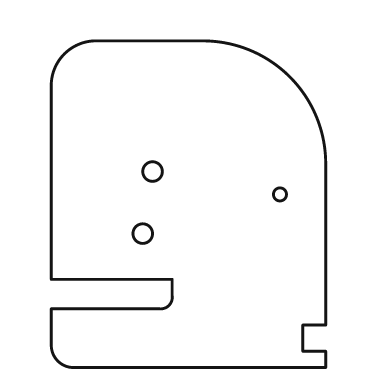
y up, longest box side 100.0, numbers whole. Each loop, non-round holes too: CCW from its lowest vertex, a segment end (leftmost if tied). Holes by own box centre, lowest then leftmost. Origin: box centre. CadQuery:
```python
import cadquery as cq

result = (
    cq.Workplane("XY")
    .moveTo(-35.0, -50.0)
    .lineTo(42.0, -50.0)
    .lineTo(42.0, -45.0)
    .lineTo(35.0, -45.0)
    .lineTo(35.0, -37.0)
    .lineTo(42.0, -37.0)
    .lineTo(42.0, 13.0)
    .threePointArc((31.0, 39.0), (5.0, 50.0))
    .lineTo(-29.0, 50.0)
    .threePointArc((-38.0, 46.0), (-42.0, 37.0))
    .lineTo(-42.0, -23.0)
    .lineTo(-5.0, -23.0)
    .lineTo(-5.0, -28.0)
    .threePointArc((-6.0, -31.0), (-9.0, -32.0))
    .lineTo(-42.0, -32.0)
    .lineTo(-42.0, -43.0)
    .threePointArc((-40.0, -48.0), (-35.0, -50.0))
    .close()
    .moveTo(-14.0, -9.0)
    .circle(3.0)
    .moveTo(28.0, 3.0)
    .circle(2.0)
    .moveTo(-11.0, 10.0)
    .circle(3.0)
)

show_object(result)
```